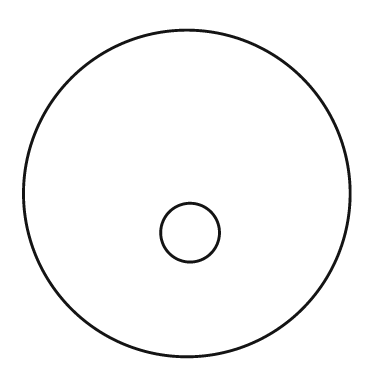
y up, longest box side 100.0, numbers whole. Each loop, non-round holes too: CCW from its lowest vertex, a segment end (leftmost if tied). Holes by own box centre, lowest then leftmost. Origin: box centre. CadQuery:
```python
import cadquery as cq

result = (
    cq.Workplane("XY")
    .moveTo(0.0, 0.0)
    .circle(50.0)
    .moveTo(1.0, -12.0)
    .circle(9.0)
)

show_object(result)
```